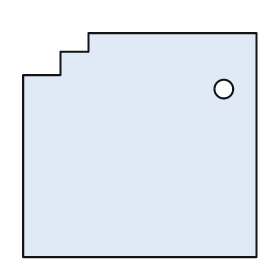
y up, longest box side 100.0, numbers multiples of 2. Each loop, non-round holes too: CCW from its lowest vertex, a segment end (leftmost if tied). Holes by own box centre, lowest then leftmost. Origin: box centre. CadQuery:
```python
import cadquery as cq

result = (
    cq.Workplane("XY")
    .moveTo(-50.0, -48.0)
    .lineTo(50.0, -48.0)
    .lineTo(50.0, 48.0)
    .lineTo(-22.0, 48.0)
    .lineTo(-22.0, 40.0)
    .lineTo(-34.0, 40.0)
    .lineTo(-34.0, 30.0)
    .lineTo(-50.0, 30.0)
    .close()
    .moveTo(36.0, 24.0)
    .circle(4.0)
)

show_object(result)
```